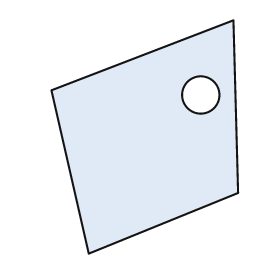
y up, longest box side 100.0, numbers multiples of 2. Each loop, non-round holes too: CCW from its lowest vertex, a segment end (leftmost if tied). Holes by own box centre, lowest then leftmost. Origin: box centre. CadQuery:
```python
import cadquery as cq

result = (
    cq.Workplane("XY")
    .moveTo(-24.0, -50.0)
    .lineTo(40.0, -24.0)
    .lineTo(38.0, 50.0)
    .lineTo(-40.0, 20.0)
    .close()
    .moveTo(24.0, 18.0)
    .circle(8.0)
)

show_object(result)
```